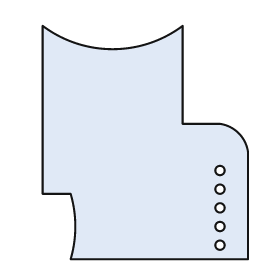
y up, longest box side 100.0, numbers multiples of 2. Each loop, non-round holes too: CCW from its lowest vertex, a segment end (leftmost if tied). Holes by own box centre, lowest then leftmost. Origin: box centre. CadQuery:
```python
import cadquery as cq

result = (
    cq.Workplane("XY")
    .moveTo(-32.0, -50.0)
    .lineTo(44.0, -50.0)
    .lineTo(44.0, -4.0)
    .threePointArc((40.0, 4.0), (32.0, 8.0))
    .lineTo(16.0, 8.0)
    .lineTo(16.0, 50.0)
    .threePointArc((-14.0, 40.0), (-44.0, 50.0))
    .lineTo(-44.0, -22.0)
    .lineTo(-32.0, -22.0)
    .threePointArc((-30.0, -36.0), (-32.0, -50.0))
    .close()
    .moveTo(32.0, -44.0)
    .circle(2.0)
    .moveTo(32.0, -36.0)
    .circle(2.0)
    .moveTo(32.0, -28.0)
    .circle(2.0)
    .moveTo(32.0, -20.0)
    .circle(2.0)
    .moveTo(32.0, -12.0)
    .circle(2.0)
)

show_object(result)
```